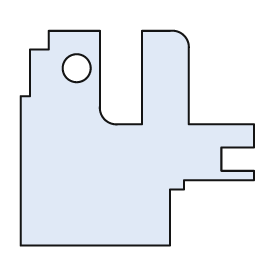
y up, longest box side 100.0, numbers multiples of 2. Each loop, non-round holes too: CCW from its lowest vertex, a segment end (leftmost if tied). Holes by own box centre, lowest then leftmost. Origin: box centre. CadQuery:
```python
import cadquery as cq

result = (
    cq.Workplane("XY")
    .moveTo(-50.0, -46.0)
    .lineTo(14.0, -46.0)
    .lineTo(14.0, -22.0)
    .lineTo(20.0, -22.0)
    .lineTo(20.0, -18.0)
    .lineTo(50.0, -18.0)
    .lineTo(50.0, -14.0)
    .lineTo(36.0, -14.0)
    .lineTo(36.0, -4.0)
    .lineTo(50.0, -4.0)
    .lineTo(50.0, 6.0)
    .lineTo(22.0, 6.0)
    .lineTo(22.0, 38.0)
    .threePointArc((20.0, 44.0), (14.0, 46.0))
    .lineTo(2.0, 46.0)
    .lineTo(2.0, 6.0)
    .lineTo(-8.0, 6.0)
    .threePointArc((-14.0, 8.0), (-16.0, 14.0))
    .lineTo(-16.0, 46.0)
    .lineTo(-38.0, 46.0)
    .lineTo(-38.0, 38.0)
    .lineTo(-46.0, 38.0)
    .lineTo(-46.0, 18.0)
    .lineTo(-50.0, 18.0)
    .close()
    .moveTo(-26.0, 30.0)
    .circle(6.0)
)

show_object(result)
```